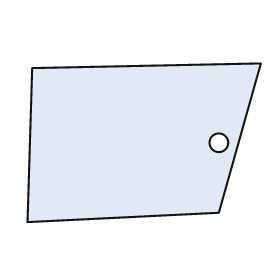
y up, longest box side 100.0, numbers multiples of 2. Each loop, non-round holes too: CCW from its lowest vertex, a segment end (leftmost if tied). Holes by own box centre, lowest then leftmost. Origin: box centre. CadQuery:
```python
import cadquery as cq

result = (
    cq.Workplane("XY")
    .moveTo(-50.0, -34.0)
    .lineTo(32.0, -30.0)
    .lineTo(50.0, 34.0)
    .lineTo(-48.0, 32.0)
    .close()
    .moveTo(32.0, 0.0)
    .circle(4.0)
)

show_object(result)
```